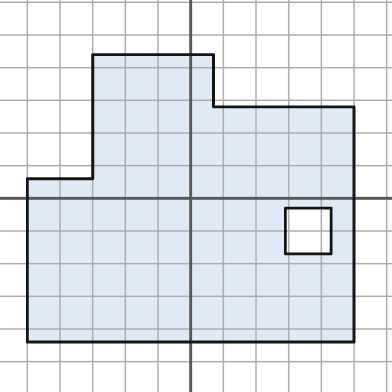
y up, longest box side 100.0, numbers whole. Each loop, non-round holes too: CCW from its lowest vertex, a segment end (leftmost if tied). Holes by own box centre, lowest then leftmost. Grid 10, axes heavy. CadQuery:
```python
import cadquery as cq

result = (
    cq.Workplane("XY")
    .moveTo(-50.0, -44.0)
    .lineTo(50.0, -44.0)
    .lineTo(50.0, 28.0)
    .lineTo(7.0, 28.0)
    .lineTo(7.0, 44.0)
    .lineTo(-30.0, 44.0)
    .lineTo(-30.0, 6.0)
    .lineTo(-50.0, 6.0)
    .close()
    .moveTo(29.0, -17.0)
    .lineTo(43.0, -17.0)
    .lineTo(43.0, -3.0)
    .lineTo(29.0, -3.0)
    .close()
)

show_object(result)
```